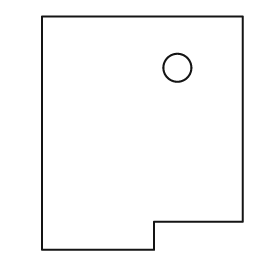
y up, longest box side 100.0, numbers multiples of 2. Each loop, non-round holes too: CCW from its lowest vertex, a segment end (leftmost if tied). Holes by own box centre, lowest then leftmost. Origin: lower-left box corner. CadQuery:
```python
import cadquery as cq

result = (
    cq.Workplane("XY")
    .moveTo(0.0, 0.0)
    .lineTo(48.0, 0.0)
    .lineTo(48.0, 12.0)
    .lineTo(86.0, 12.0)
    .lineTo(86.0, 100.0)
    .lineTo(0.0, 100.0)
    .close()
    .moveTo(58.0, 78.0)
    .circle(6.0)
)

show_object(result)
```